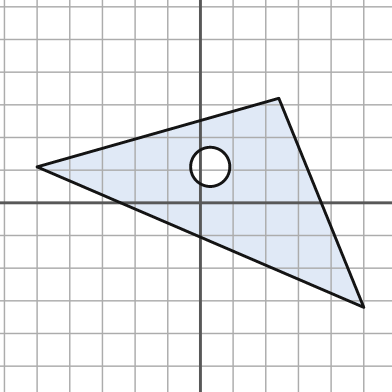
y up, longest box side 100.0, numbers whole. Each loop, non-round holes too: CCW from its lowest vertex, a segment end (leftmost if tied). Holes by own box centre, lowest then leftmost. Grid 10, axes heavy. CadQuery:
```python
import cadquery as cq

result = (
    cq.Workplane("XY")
    .moveTo(50.0, -32.0)
    .lineTo(24.0, 32.0)
    .lineTo(-50.0, 11.0)
    .close()
    .moveTo(3.0, 11.0)
    .circle(6.0)
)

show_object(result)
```